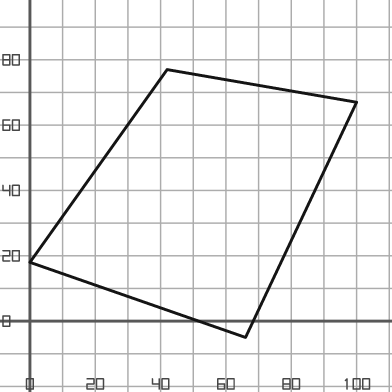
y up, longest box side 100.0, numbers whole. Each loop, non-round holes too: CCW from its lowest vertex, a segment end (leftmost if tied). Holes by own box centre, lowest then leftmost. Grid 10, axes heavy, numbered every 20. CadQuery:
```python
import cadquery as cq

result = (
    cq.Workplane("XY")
    .moveTo(66.0, -5.0)
    .lineTo(100.0, 67.0)
    .lineTo(42.0, 77.0)
    .lineTo(0.0, 18.0)
    .close()
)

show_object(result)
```